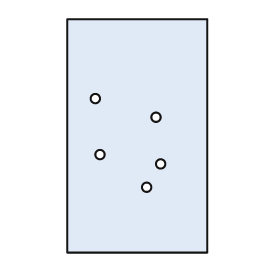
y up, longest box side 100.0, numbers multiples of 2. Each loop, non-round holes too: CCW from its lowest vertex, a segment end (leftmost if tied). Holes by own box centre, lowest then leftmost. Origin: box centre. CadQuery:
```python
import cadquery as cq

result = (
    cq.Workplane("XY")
    .moveTo(-30.0, -50.0)
    .lineTo(30.0, -50.0)
    .lineTo(30.0, 50.0)
    .lineTo(-30.0, 50.0)
    .close()
    .moveTo(4.0, -22.0)
    .circle(2.0)
    .moveTo(10.0, -12.0)
    .circle(2.0)
    .moveTo(-16.0, -8.0)
    .circle(2.0)
    .moveTo(8.0, 8.0)
    .circle(2.0)
    .moveTo(-18.0, 16.0)
    .circle(2.0)
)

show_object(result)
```